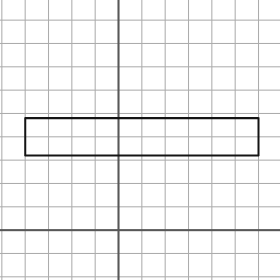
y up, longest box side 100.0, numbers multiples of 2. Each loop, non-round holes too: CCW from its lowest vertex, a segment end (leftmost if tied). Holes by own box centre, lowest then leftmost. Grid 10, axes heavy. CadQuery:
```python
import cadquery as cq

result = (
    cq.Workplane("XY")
    .moveTo(-40.0, 32.0)
    .lineTo(60.0, 32.0)
    .lineTo(60.0, 48.0)
    .lineTo(-40.0, 48.0)
    .close()
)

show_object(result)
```